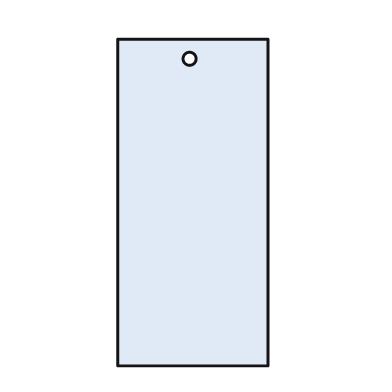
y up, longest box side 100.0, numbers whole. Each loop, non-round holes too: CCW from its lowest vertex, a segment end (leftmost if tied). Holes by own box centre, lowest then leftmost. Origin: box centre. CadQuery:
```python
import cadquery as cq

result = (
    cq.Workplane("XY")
    .moveTo(-23.0, -50.0)
    .lineTo(23.0, -50.0)
    .lineTo(23.0, 50.0)
    .lineTo(-23.0, 50.0)
    .close()
    .moveTo(-1.0, 44.0)
    .circle(2.0)
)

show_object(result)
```